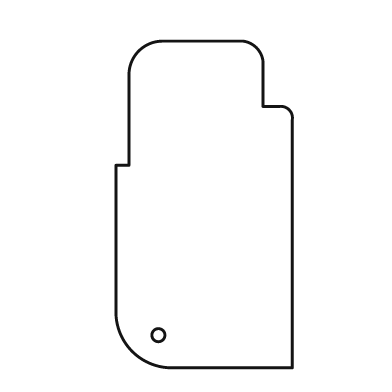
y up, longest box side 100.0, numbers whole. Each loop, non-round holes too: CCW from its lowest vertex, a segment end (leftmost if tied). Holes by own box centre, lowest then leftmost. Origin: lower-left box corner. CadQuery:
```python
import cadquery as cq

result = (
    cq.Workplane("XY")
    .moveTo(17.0, 0.0)
    .lineTo(54.0, 0.0)
    .lineTo(54.0, 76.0)
    .threePointArc((53.0, 79.0), (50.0, 80.0))
    .lineTo(45.0, 80.0)
    .lineTo(45.0, 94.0)
    .threePointArc((43.0, 98.0), (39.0, 100.0))
    .lineTo(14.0, 100.0)
    .threePointArc((7.0, 97.0), (4.0, 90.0))
    .lineTo(4.0, 62.0)
    .lineTo(0.0, 62.0)
    .lineTo(0.0, 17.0)
    .threePointArc((5.0, 5.0), (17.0, 0.0))
    .close()
    .moveTo(13.0, 10.0)
    .circle(2.0)
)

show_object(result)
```